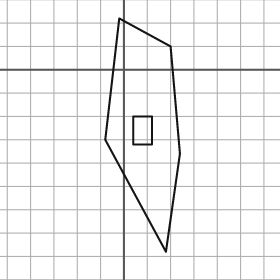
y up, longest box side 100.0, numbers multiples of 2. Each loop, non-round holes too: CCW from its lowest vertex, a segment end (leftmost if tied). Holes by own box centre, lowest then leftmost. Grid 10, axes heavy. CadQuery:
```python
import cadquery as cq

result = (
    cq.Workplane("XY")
    .moveTo(18.0, -78.0)
    .lineTo(24.0, -36.0)
    .lineTo(20.0, 10.0)
    .lineTo(-2.0, 22.0)
    .lineTo(-8.0, -30.0)
    .close()
    .moveTo(4.0, -32.0)
    .lineTo(12.0, -32.0)
    .lineTo(12.0, -20.0)
    .lineTo(4.0, -20.0)
    .close()
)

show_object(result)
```